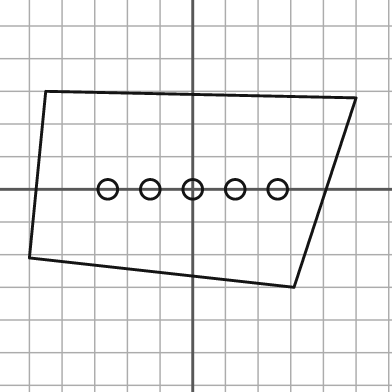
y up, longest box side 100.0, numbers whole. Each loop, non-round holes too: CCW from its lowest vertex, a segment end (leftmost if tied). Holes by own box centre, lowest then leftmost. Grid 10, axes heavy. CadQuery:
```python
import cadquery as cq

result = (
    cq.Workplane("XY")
    .moveTo(31.0, -30.0)
    .lineTo(50.0, 28.0)
    .lineTo(-45.0, 30.0)
    .lineTo(-50.0, -21.0)
    .close()
    .moveTo(-26.0, 0.0)
    .circle(3.0)
    .moveTo(-13.0, 0.0)
    .circle(3.0)
    .moveTo(0.0, 0.0)
    .circle(3.0)
    .moveTo(13.0, 0.0)
    .circle(3.0)
    .moveTo(26.0, 0.0)
    .circle(3.0)
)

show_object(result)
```